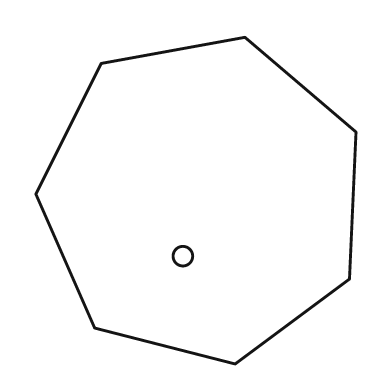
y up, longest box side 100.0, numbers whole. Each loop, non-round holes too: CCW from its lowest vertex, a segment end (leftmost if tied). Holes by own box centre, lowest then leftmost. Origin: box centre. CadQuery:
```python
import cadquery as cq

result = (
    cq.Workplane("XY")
    .moveTo(12.0, -50.0)
    .lineTo(47.0, -24.0)
    .lineTo(49.0, 21.0)
    .lineTo(15.0, 50.0)
    .lineTo(-29.0, 42.0)
    .lineTo(-49.0, 2.0)
    .lineTo(-31.0, -39.0)
    .close()
    .moveTo(-4.0, -17.0)
    .circle(3.0)
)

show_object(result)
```